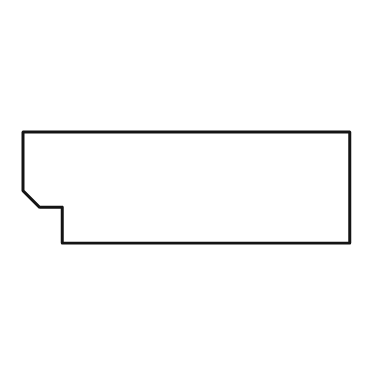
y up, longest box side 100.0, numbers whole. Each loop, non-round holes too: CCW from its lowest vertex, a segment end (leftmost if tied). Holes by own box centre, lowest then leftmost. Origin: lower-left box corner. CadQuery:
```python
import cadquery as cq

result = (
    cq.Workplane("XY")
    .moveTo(12.0, 0.0)
    .lineTo(100.0, 0.0)
    .lineTo(100.0, 34.0)
    .lineTo(0.0, 34.0)
    .lineTo(0.0, 16.0)
    .lineTo(5.0, 11.0)
    .lineTo(12.0, 11.0)
    .close()
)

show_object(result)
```